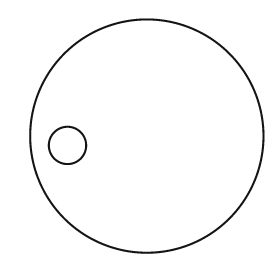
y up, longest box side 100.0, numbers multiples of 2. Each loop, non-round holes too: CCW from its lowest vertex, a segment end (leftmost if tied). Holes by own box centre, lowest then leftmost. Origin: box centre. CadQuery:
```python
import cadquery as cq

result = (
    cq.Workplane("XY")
    .moveTo(0.0, 0.0)
    .circle(50.0)
    .moveTo(-34.0, -4.0)
    .circle(8.0)
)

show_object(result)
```